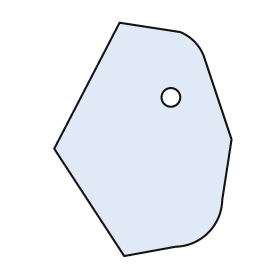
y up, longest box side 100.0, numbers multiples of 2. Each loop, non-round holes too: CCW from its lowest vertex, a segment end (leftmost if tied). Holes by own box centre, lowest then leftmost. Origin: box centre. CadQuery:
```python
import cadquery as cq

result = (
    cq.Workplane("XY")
    .moveTo(-8.0, -50.0)
    .lineTo(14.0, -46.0)
    .threePointArc((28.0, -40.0), (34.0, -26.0))
    .lineTo(38.0, 0.0)
    .lineTo(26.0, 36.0)
    .threePointArc((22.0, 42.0), (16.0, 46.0))
    .lineTo(-10.0, 50.0)
    .lineTo(-38.0, -4.0)
    .close()
    .moveTo(12.0, 18.0)
    .circle(4.0)
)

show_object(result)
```